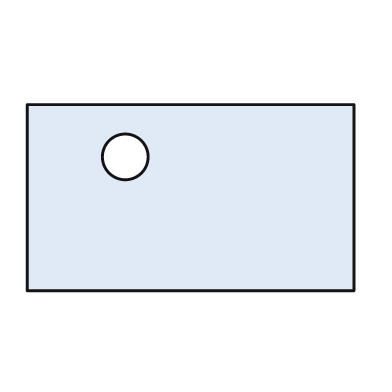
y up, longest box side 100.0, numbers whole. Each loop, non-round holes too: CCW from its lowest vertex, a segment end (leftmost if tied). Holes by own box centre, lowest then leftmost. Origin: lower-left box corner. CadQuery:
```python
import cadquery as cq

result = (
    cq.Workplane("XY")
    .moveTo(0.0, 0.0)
    .lineTo(100.0, 0.0)
    .lineTo(100.0, 57.0)
    .lineTo(0.0, 57.0)
    .close()
    .moveTo(30.0, 41.0)
    .circle(7.0)
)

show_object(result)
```